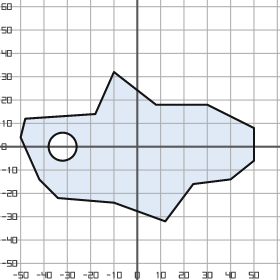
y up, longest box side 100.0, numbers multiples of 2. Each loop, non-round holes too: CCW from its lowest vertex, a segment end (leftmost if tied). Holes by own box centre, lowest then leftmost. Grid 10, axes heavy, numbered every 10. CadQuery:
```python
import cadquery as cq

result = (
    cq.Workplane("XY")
    .moveTo(12.0, -32.0)
    .lineTo(24.0, -16.0)
    .lineTo(40.0, -14.0)
    .lineTo(50.0, -6.0)
    .lineTo(50.0, 8.0)
    .lineTo(30.0, 18.0)
    .lineTo(8.0, 18.0)
    .lineTo(-10.0, 32.0)
    .lineTo(-18.0, 14.0)
    .lineTo(-48.0, 12.0)
    .lineTo(-50.0, 4.0)
    .lineTo(-42.0, -14.0)
    .lineTo(-34.0, -22.0)
    .lineTo(-10.0, -24.0)
    .close()
    .moveTo(-32.0, 0.0)
    .circle(6.0)
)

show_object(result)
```